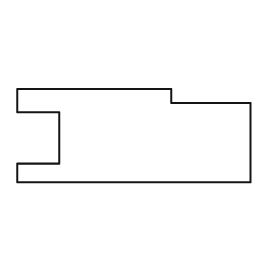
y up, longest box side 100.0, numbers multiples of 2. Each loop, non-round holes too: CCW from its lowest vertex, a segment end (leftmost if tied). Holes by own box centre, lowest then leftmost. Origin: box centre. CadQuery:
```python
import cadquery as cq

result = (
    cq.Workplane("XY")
    .moveTo(-50.0, -20.0)
    .lineTo(50.0, -20.0)
    .lineTo(50.0, 14.0)
    .lineTo(16.0, 14.0)
    .lineTo(16.0, 20.0)
    .lineTo(-50.0, 20.0)
    .lineTo(-50.0, 10.0)
    .lineTo(-32.0, 10.0)
    .lineTo(-32.0, -12.0)
    .lineTo(-50.0, -12.0)
    .close()
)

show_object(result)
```